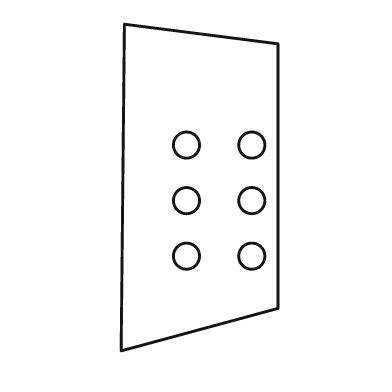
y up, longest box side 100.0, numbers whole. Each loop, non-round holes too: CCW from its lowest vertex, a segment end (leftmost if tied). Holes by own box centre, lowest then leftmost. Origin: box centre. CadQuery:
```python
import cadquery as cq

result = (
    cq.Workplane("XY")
    .moveTo(-24.0, -50.0)
    .lineTo(24.0, -37.0)
    .lineTo(24.0, 44.0)
    .lineTo(-23.0, 50.0)
    .close()
    .moveTo(-4.0, -21.0)
    .circle(4.0)
    .moveTo(16.0, -21.0)
    .circle(4.0)
    .moveTo(-4.0, -4.0)
    .circle(4.0)
    .moveTo(16.0, -4.0)
    .circle(4.0)
    .moveTo(-4.0, 13.0)
    .circle(4.0)
    .moveTo(16.0, 13.0)
    .circle(4.0)
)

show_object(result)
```